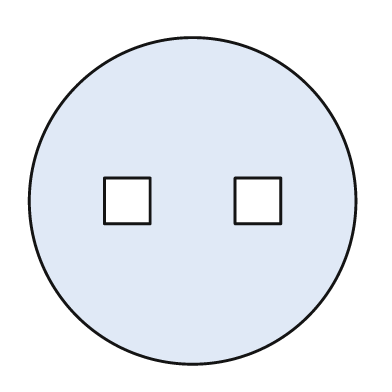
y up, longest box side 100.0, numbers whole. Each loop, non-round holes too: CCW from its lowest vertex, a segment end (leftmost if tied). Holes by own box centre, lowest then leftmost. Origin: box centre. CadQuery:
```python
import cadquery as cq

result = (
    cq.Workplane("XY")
    .moveTo(0.0, 0.0)
    .circle(50.0)
    .moveTo(-27.0, -7.0)
    .lineTo(-13.0, -7.0)
    .lineTo(-13.0, 7.0)
    .lineTo(-27.0, 7.0)
    .close()
    .moveTo(13.0, -7.0)
    .lineTo(27.0, -7.0)
    .lineTo(27.0, 7.0)
    .lineTo(13.0, 7.0)
    .close()
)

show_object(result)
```